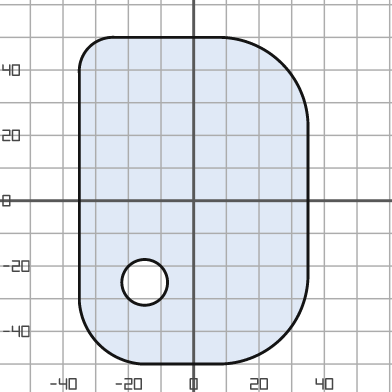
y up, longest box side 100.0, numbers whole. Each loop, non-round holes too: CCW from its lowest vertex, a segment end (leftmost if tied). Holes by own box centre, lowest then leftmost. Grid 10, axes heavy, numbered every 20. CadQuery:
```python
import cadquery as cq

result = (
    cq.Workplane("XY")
    .moveTo(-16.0, -50.0)
    .lineTo(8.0, -50.0)
    .threePointArc((27.0, -42.0), (35.0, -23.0))
    .lineTo(35.0, 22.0)
    .threePointArc((27.0, 42.0), (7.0, 50.0))
    .lineTo(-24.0, 50.0)
    .threePointArc((-32.0, 47.0), (-35.0, 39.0))
    .lineTo(-35.0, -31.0)
    .threePointArc((-29.0, -44.0), (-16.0, -50.0))
    .close()
    .moveTo(-15.0, -25.0)
    .circle(7.0)
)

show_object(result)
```